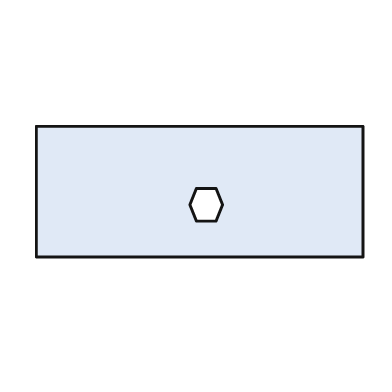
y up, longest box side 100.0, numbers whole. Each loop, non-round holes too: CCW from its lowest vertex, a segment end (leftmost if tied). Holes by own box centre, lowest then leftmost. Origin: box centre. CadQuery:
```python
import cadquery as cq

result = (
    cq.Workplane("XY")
    .moveTo(-50.0, -20.0)
    .lineTo(50.0, -20.0)
    .lineTo(50.0, 20.0)
    .lineTo(-50.0, 20.0)
    .close()
    .moveTo(-1.0, -9.0)
    .lineTo(5.0, -9.0)
    .lineTo(7.0, -4.0)
    .lineTo(5.0, 1.0)
    .lineTo(-1.0, 1.0)
    .lineTo(-3.0, -4.0)
    .close()
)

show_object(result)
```